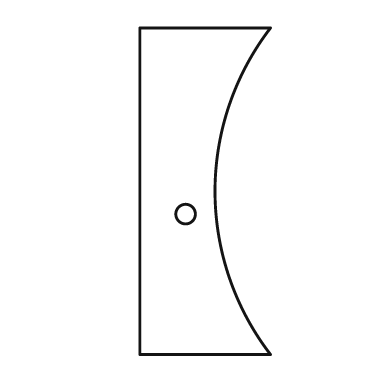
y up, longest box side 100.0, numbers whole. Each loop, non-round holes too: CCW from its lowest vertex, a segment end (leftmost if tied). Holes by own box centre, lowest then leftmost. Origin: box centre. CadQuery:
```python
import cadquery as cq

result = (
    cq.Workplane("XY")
    .moveTo(-20.0, -50.0)
    .lineTo(20.0, -50.0)
    .threePointArc((3.0, 0.0), (20.0, 50.0))
    .lineTo(-20.0, 50.0)
    .close()
    .moveTo(-6.0, -7.0)
    .circle(3.0)
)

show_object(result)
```